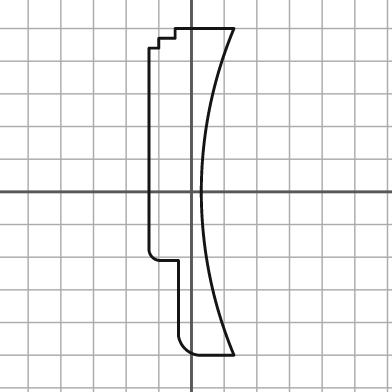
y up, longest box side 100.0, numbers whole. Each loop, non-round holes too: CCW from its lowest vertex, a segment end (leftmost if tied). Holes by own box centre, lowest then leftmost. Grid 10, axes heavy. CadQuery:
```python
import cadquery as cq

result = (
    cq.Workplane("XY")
    .moveTo(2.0, -50.0)
    .lineTo(13.0, -50.0)
    .threePointArc((3.0, 0.0), (13.0, 50.0))
    .lineTo(-5.0, 50.0)
    .lineTo(-5.0, 47.0)
    .lineTo(-10.0, 47.0)
    .lineTo(-10.0, 44.0)
    .lineTo(-13.0, 44.0)
    .lineTo(-13.0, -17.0)
    .threePointArc((-12.0, -20.0), (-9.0, -21.0))
    .lineTo(-4.0, -21.0)
    .lineTo(-4.0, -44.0)
    .threePointArc((-2.0, -48.0), (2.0, -50.0))
    .close()
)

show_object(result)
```